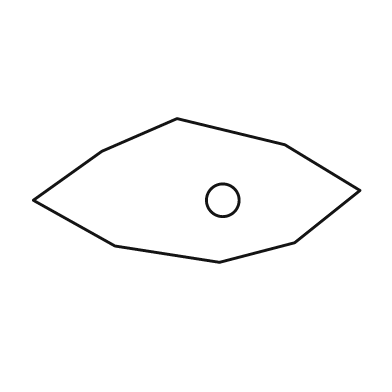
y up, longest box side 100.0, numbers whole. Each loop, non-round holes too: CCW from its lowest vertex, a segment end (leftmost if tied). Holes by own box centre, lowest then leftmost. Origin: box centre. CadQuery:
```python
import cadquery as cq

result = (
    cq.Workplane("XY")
    .moveTo(7.0, -22.0)
    .lineTo(30.0, -16.0)
    .lineTo(50.0, 0.0)
    .lineTo(27.0, 14.0)
    .lineTo(-6.0, 22.0)
    .lineTo(-29.0, 12.0)
    .lineTo(-50.0, -3.0)
    .lineTo(-25.0, -17.0)
    .close()
    .moveTo(8.0, -3.0)
    .circle(5.0)
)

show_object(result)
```